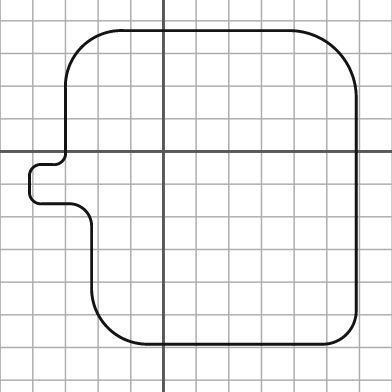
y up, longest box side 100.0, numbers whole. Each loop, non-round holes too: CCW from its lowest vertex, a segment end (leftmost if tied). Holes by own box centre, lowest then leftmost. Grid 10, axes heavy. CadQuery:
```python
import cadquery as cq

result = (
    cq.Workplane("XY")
    .moveTo(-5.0, -59.0)
    .lineTo(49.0, -59.0)
    .threePointArc((56.0, -56.0), (59.0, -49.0))
    .lineTo(59.0, 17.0)
    .threePointArc((53.0, 31.0), (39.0, 37.0))
    .lineTo(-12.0, 37.0)
    .threePointArc((-25.0, 32.0), (-30.0, 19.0))
    .lineTo(-30.0, 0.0)
    .threePointArc((-31.0, -3.0), (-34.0, -4.0))
    .lineTo(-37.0, -4.0)
    .threePointArc((-40.0, -5.0), (-41.0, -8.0))
    .lineTo(-41.0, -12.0)
    .threePointArc((-40.0, -15.0), (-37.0, -16.0))
    .lineTo(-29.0, -16.0)
    .threePointArc((-24.0, -18.0), (-22.0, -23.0))
    .lineTo(-22.0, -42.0)
    .threePointArc((-17.0, -54.0), (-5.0, -59.0))
    .close()
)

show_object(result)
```